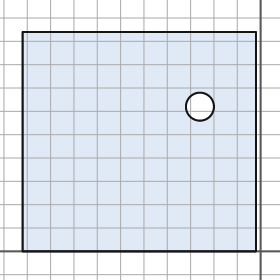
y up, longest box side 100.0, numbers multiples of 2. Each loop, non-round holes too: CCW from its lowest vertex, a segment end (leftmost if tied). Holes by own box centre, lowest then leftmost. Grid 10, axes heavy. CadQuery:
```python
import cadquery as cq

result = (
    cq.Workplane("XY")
    .moveTo(-102.0, 0.0)
    .lineTo(-2.0, 0.0)
    .lineTo(-2.0, 94.0)
    .lineTo(-102.0, 94.0)
    .close()
    .moveTo(-26.0, 62.0)
    .circle(6.0)
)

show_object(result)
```